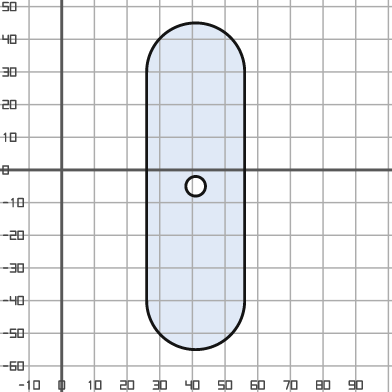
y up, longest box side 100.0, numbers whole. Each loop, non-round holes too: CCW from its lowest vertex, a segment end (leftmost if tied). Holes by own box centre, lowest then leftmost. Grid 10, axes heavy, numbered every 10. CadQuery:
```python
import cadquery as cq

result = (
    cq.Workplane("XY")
    .moveTo(26.0, -40.0)
    .threePointArc((41.0, -55.0), (56.0, -40.0))
    .lineTo(56.0, 30.0)
    .threePointArc((41.0, 45.0), (26.0, 30.0))
    .close()
    .moveTo(41.0, -5.0)
    .circle(3.0)
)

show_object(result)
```